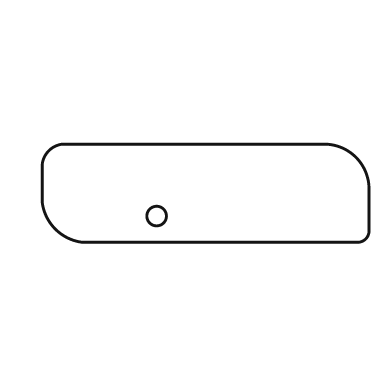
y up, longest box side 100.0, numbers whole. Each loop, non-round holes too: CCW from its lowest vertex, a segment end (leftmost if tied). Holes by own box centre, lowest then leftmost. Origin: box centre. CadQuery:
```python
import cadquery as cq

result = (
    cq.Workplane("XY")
    .moveTo(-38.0, -15.0)
    .lineTo(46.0, -15.0)
    .threePointArc((49.0, -14.0), (50.0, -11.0))
    .lineTo(50.0, 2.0)
    .threePointArc((46.0, 11.0), (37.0, 15.0))
    .lineTo(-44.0, 15.0)
    .threePointArc((-48.0, 13.0), (-50.0, 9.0))
    .lineTo(-50.0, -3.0)
    .threePointArc((-46.0, -11.0), (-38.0, -15.0))
    .close()
    .moveTo(-15.0, -7.0)
    .circle(3.0)
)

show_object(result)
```